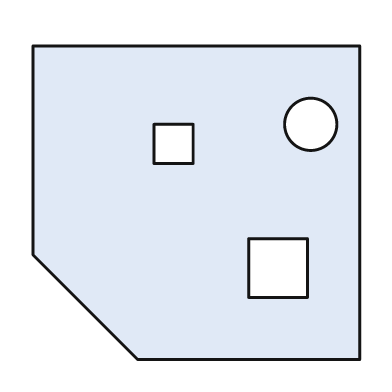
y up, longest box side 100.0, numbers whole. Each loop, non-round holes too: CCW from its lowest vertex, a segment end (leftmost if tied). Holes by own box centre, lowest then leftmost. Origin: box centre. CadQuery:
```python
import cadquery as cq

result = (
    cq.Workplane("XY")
    .moveTo(-18.0, -48.0)
    .lineTo(50.0, -48.0)
    .lineTo(50.0, 48.0)
    .lineTo(-50.0, 48.0)
    .lineTo(-50.0, -16.0)
    .close()
    .moveTo(16.0, -29.0)
    .lineTo(34.0, -29.0)
    .lineTo(34.0, -11.0)
    .lineTo(16.0, -11.0)
    .close()
    .moveTo(-13.0, 12.0)
    .lineTo(-1.0, 12.0)
    .lineTo(-1.0, 24.0)
    .lineTo(-13.0, 24.0)
    .close()
    .moveTo(35.0, 24.0)
    .circle(8.0)
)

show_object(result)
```